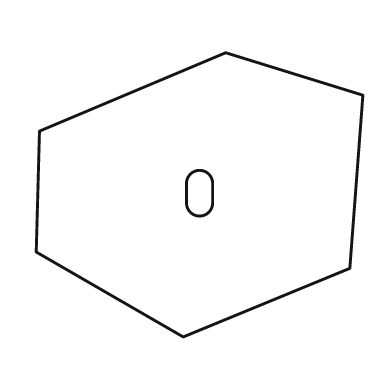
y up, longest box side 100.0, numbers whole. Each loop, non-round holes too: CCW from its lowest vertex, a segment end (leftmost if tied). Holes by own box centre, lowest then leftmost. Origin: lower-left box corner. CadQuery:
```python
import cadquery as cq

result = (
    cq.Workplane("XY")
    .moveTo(45.0, 0.0)
    .lineTo(96.0, 21.0)
    .lineTo(100.0, 74.0)
    .lineTo(58.0, 87.0)
    .lineTo(1.0, 63.0)
    .lineTo(0.0, 26.0)
    .close()
    .moveTo(46.0, 41.0)
    .threePointArc((50.0, 37.0), (54.0, 41.0))
    .lineTo(54.0, 47.0)
    .threePointArc((50.0, 51.0), (46.0, 47.0))
    .close()
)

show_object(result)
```